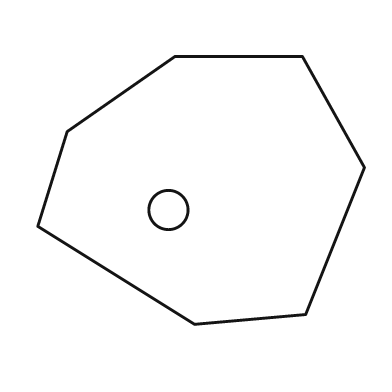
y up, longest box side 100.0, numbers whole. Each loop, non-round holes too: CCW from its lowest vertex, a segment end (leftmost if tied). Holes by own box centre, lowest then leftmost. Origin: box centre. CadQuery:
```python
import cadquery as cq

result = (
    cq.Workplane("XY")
    .moveTo(-2.0, -41.0)
    .lineTo(32.0, -38.0)
    .lineTo(50.0, 7.0)
    .lineTo(31.0, 41.0)
    .lineTo(-8.0, 41.0)
    .lineTo(-41.0, 18.0)
    .lineTo(-50.0, -11.0)
    .close()
    .moveTo(-10.0, -6.0)
    .circle(6.0)
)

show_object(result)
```